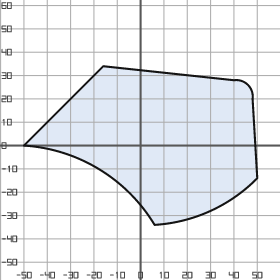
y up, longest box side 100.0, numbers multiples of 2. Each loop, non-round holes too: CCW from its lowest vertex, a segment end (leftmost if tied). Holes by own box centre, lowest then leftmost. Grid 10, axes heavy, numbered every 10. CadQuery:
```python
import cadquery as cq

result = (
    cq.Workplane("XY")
    .moveTo(6.0, -34.0)
    .threePointArc((30.0, -28.0), (50.0, -14.0))
    .lineTo(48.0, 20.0)
    .threePointArc((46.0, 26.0), (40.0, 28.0))
    .lineTo(-16.0, 34.0)
    .lineTo(-50.0, 0.0)
    .threePointArc((-18.0, -10.0), (6.0, -34.0))
    .close()
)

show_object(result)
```